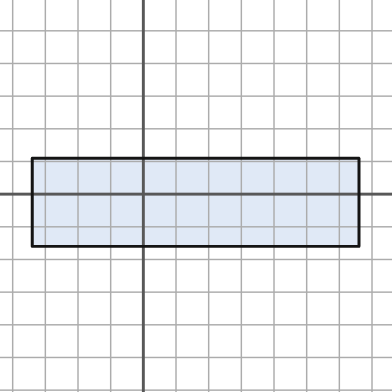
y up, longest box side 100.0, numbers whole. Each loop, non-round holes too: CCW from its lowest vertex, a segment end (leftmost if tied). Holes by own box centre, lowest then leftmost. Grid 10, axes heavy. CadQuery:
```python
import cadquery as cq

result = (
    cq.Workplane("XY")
    .moveTo(-34.0, -16.0)
    .lineTo(66.0, -16.0)
    .lineTo(66.0, 11.0)
    .lineTo(-34.0, 11.0)
    .close()
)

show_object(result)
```